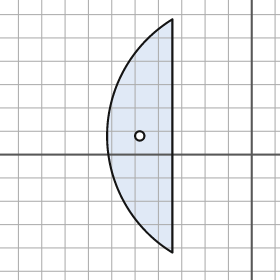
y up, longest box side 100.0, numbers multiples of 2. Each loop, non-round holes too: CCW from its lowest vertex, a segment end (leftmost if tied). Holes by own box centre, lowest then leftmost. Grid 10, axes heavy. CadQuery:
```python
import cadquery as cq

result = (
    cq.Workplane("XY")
    .moveTo(-34.0, -42.0)
    .lineTo(-34.0, 58.0)
    .threePointArc((-62.0, 8.0), (-34.0, -42.0))
    .close()
    .moveTo(-48.0, 8.0)
    .circle(2.0)
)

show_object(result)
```